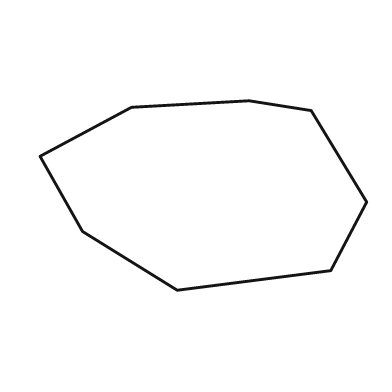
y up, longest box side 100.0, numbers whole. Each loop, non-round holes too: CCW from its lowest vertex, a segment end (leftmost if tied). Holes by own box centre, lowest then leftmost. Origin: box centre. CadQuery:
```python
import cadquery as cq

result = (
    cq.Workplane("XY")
    .moveTo(-8.0, -29.0)
    .lineTo(39.0, -23.0)
    .lineTo(50.0, -2.0)
    .lineTo(33.0, 26.0)
    .lineTo(14.0, 29.0)
    .lineTo(-22.0, 27.0)
    .lineTo(-50.0, 12.0)
    .lineTo(-37.0, -11.0)
    .close()
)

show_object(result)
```